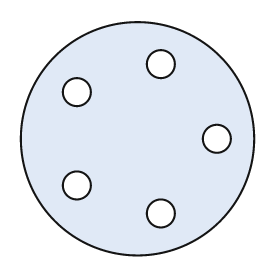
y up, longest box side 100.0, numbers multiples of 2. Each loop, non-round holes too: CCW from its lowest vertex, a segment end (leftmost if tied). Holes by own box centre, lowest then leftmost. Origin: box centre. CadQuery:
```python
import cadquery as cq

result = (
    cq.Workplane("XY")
    .moveTo(0.0, 0.0)
    .circle(50.0)
    .moveTo(10.0, -32.0)
    .circle(6.0)
    .moveTo(-26.0, -20.0)
    .circle(6.0)
    .moveTo(34.0, 0.0)
    .circle(6.0)
    .moveTo(-26.0, 20.0)
    .circle(6.0)
    .moveTo(10.0, 32.0)
    .circle(6.0)
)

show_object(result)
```